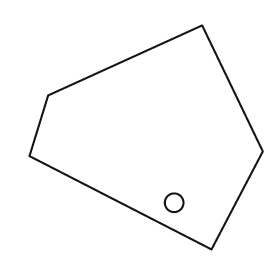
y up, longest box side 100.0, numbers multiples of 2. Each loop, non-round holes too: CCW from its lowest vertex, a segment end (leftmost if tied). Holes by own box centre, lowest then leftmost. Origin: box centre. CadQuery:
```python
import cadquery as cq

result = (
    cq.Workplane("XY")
    .moveTo(28.0, -48.0)
    .lineTo(50.0, -6.0)
    .lineTo(24.0, 48.0)
    .lineTo(-42.0, 18.0)
    .lineTo(-50.0, -8.0)
    .close()
    .moveTo(12.0, -28.0)
    .circle(4.0)
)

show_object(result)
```